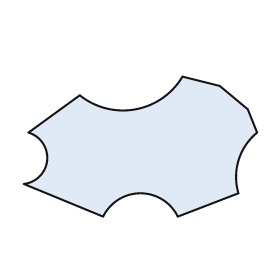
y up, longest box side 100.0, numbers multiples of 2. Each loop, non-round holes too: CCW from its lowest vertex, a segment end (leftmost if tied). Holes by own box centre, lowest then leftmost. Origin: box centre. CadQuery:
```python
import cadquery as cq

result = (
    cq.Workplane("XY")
    .moveTo(-16.0, -30.0)
    .threePointArc((0.0, -20.0), (16.0, -30.0))
    .lineTo(42.0, -20.0)
    .threePointArc((42.0, -6.0), (50.0, 6.0))
    .lineTo(46.0, 16.0)
    .lineTo(34.0, 26.0)
    .lineTo(18.0, 30.0)
    .threePointArc((-2.0, 16.0), (-26.0, 22.0))
    .lineTo(-48.0, 6.0)
    .threePointArc((-40.0, -6.0), (-50.0, -16.0))
    .close()
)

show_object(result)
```